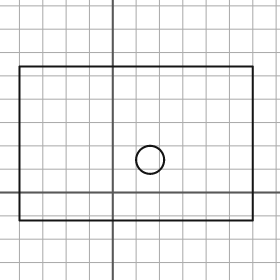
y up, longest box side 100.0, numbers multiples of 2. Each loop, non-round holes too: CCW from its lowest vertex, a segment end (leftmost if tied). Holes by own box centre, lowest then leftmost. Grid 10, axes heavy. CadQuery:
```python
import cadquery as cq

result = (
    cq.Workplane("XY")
    .moveTo(-40.0, -12.0)
    .lineTo(60.0, -12.0)
    .lineTo(60.0, 54.0)
    .lineTo(-40.0, 54.0)
    .close()
    .moveTo(16.0, 14.0)
    .circle(6.0)
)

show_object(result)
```